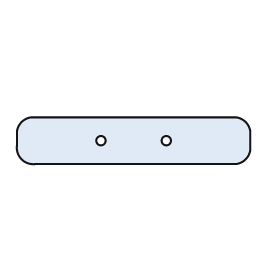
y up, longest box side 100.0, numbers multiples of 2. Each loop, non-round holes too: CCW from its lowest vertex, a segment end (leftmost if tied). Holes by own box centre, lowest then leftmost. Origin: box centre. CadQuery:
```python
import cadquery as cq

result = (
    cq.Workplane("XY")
    .moveTo(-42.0, -10.0)
    .lineTo(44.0, -10.0)
    .threePointArc((48.0, -8.0), (50.0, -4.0))
    .lineTo(50.0, 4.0)
    .threePointArc((48.0, 8.0), (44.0, 10.0))
    .lineTo(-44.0, 10.0)
    .threePointArc((-48.0, 8.0), (-50.0, 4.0))
    .lineTo(-50.0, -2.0)
    .threePointArc((-48.0, -8.0), (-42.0, -10.0))
    .close()
    .moveTo(-14.0, 0.0)
    .circle(2.0)
    .moveTo(14.0, 0.0)
    .circle(2.0)
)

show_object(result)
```